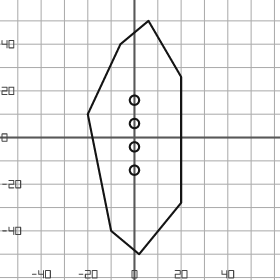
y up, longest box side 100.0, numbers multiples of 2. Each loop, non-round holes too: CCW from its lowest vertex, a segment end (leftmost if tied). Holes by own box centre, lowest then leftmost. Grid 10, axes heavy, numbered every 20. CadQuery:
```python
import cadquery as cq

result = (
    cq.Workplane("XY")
    .moveTo(2.0, -50.0)
    .lineTo(20.0, -28.0)
    .lineTo(20.0, 26.0)
    .lineTo(6.0, 50.0)
    .lineTo(-6.0, 40.0)
    .lineTo(-20.0, 10.0)
    .lineTo(-10.0, -40.0)
    .close()
    .moveTo(0.0, -14.0)
    .circle(2.0)
    .moveTo(0.0, -4.0)
    .circle(2.0)
    .moveTo(0.0, 6.0)
    .circle(2.0)
    .moveTo(0.0, 16.0)
    .circle(2.0)
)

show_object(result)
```